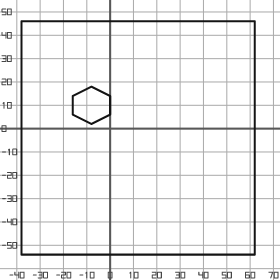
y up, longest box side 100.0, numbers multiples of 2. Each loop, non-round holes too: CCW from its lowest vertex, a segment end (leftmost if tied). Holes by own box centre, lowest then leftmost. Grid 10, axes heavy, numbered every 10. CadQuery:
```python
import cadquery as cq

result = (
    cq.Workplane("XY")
    .moveTo(-38.0, -54.0)
    .lineTo(62.0, -54.0)
    .lineTo(62.0, 46.0)
    .lineTo(-38.0, 46.0)
    .close()
    .moveTo(-8.0, 2.0)
    .lineTo(0.0, 6.0)
    .lineTo(0.0, 14.0)
    .lineTo(-8.0, 18.0)
    .lineTo(-16.0, 14.0)
    .lineTo(-16.0, 6.0)
    .close()
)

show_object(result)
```